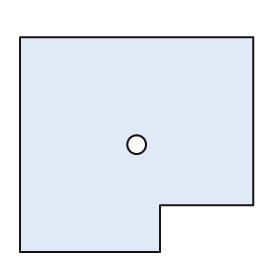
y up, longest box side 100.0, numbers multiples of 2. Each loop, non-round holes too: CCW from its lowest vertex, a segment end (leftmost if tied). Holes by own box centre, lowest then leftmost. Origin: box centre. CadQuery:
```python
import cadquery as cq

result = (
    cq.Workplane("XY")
    .moveTo(-50.0, -46.0)
    .lineTo(10.0, -46.0)
    .lineTo(10.0, -26.0)
    .lineTo(50.0, -26.0)
    .lineTo(50.0, 46.0)
    .lineTo(-50.0, 46.0)
    .close()
    .moveTo(0.0, 0.0)
    .circle(4.0)
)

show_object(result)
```